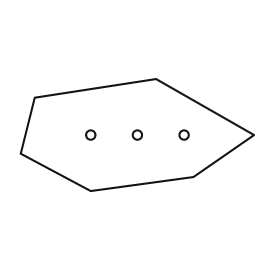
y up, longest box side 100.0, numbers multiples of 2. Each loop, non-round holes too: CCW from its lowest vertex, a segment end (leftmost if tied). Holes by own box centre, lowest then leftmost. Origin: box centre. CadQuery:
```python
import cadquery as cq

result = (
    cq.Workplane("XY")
    .moveTo(-20.0, -24.0)
    .lineTo(24.0, -18.0)
    .lineTo(50.0, 0.0)
    .lineTo(8.0, 24.0)
    .lineTo(-44.0, 16.0)
    .lineTo(-50.0, -8.0)
    .close()
    .moveTo(-20.0, 0.0)
    .circle(2.0)
    .moveTo(0.0, 0.0)
    .circle(2.0)
    .moveTo(20.0, 0.0)
    .circle(2.0)
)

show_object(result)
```